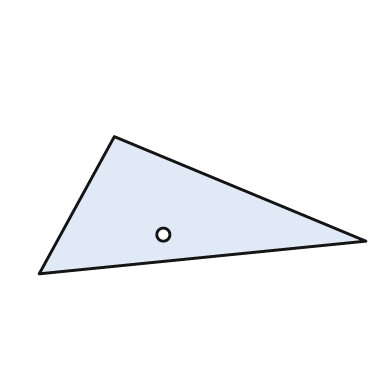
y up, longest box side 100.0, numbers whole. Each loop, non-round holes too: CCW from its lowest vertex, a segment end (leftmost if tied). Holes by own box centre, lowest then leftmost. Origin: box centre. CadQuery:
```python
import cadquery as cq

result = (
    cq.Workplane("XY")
    .moveTo(-50.0, -21.0)
    .lineTo(50.0, -11.0)
    .lineTo(-27.0, 21.0)
    .close()
    .moveTo(-12.0, -9.0)
    .circle(2.0)
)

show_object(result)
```